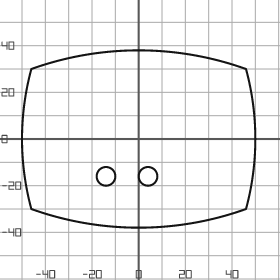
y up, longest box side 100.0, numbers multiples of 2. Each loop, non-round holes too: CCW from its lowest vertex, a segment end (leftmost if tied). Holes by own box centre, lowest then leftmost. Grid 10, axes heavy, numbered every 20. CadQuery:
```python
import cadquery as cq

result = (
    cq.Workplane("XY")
    .moveTo(-46.0, -30.0)
    .threePointArc((0.0, -38.0), (46.0, -30.0))
    .threePointArc((50.0, 0.0), (46.0, 30.0))
    .threePointArc((0.0, 38.0), (-46.0, 30.0))
    .threePointArc((-50.0, 0.0), (-46.0, -30.0))
    .close()
    .moveTo(-14.0, -16.0)
    .circle(4.0)
    .moveTo(4.0, -16.0)
    .circle(4.0)
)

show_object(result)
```